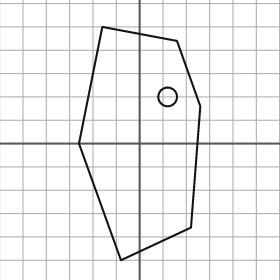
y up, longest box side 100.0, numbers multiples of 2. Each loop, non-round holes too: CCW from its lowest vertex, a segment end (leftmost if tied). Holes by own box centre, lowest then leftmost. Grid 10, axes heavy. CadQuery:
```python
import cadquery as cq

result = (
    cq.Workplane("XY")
    .moveTo(-8.0, -50.0)
    .lineTo(22.0, -36.0)
    .lineTo(26.0, 16.0)
    .lineTo(16.0, 44.0)
    .lineTo(-16.0, 50.0)
    .lineTo(-26.0, 0.0)
    .close()
    .moveTo(12.0, 20.0)
    .circle(4.0)
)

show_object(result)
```